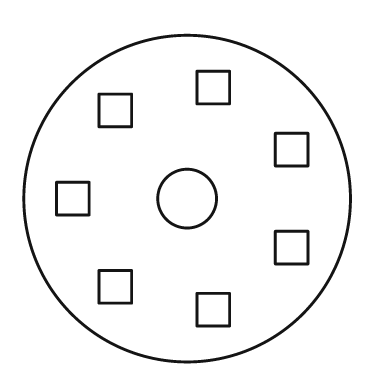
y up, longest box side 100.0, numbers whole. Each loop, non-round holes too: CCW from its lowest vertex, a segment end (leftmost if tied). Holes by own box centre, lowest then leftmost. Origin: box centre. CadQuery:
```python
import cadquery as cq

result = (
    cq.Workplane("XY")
    .moveTo(0.0, 0.0)
    .circle(50.0)
    .moveTo(3.0, -39.0)
    .lineTo(13.0, -39.0)
    .lineTo(13.0, -29.0)
    .lineTo(3.0, -29.0)
    .close()
    .moveTo(-27.0, -32.0)
    .lineTo(-17.0, -32.0)
    .lineTo(-17.0, -22.0)
    .lineTo(-27.0, -22.0)
    .close()
    .moveTo(27.0, -20.0)
    .lineTo(37.0, -20.0)
    .lineTo(37.0, -10.0)
    .lineTo(27.0, -10.0)
    .close()
    .moveTo(-40.0, -5.0)
    .lineTo(-30.0, -5.0)
    .lineTo(-30.0, 5.0)
    .lineTo(-40.0, 5.0)
    .close()
    .moveTo(0.0, 0.0)
    .circle(9.0)
    .moveTo(27.0, 10.0)
    .lineTo(37.0, 10.0)
    .lineTo(37.0, 20.0)
    .lineTo(27.0, 20.0)
    .close()
    .moveTo(-27.0, 22.0)
    .lineTo(-17.0, 22.0)
    .lineTo(-17.0, 32.0)
    .lineTo(-27.0, 32.0)
    .close()
    .moveTo(3.0, 29.0)
    .lineTo(13.0, 29.0)
    .lineTo(13.0, 39.0)
    .lineTo(3.0, 39.0)
    .close()
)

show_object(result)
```